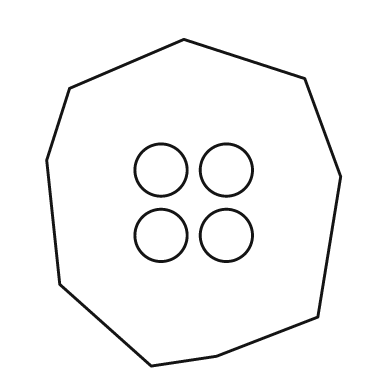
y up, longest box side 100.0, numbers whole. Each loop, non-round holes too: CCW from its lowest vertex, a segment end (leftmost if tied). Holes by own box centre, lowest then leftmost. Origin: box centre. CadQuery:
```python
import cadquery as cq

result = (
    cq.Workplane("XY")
    .moveTo(-13.0, -50.0)
    .lineTo(7.0, -47.0)
    .lineTo(38.0, -35.0)
    .lineTo(45.0, 8.0)
    .lineTo(34.0, 38.0)
    .lineTo(-3.0, 50.0)
    .lineTo(-38.0, 35.0)
    .lineTo(-45.0, 13.0)
    .lineTo(-41.0, -25.0)
    .close()
    .moveTo(-10.0, -10.0)
    .circle(8.0)
    .moveTo(10.0, -10.0)
    .circle(8.0)
    .moveTo(-10.0, 10.0)
    .circle(8.0)
    .moveTo(10.0, 10.0)
    .circle(8.0)
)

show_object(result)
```